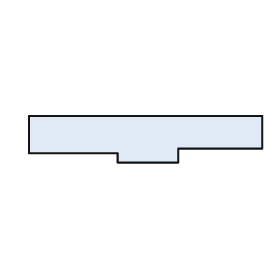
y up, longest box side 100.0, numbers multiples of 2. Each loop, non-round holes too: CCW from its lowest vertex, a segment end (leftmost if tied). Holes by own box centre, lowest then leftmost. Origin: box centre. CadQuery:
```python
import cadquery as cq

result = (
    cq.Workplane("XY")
    .moveTo(-12.0, -10.0)
    .lineTo(14.0, -10.0)
    .lineTo(14.0, -4.0)
    .lineTo(50.0, -4.0)
    .lineTo(50.0, 10.0)
    .lineTo(-50.0, 10.0)
    .lineTo(-50.0, -6.0)
    .lineTo(-12.0, -6.0)
    .close()
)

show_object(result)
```